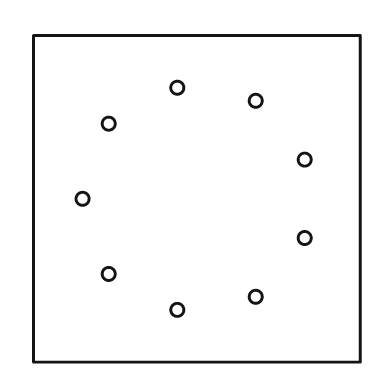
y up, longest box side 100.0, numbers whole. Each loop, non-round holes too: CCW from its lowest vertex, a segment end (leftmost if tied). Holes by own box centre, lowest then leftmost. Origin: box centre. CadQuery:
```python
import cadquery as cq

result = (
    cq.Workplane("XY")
    .moveTo(-50.0, -50.0)
    .lineTo(50.0, -50.0)
    .lineTo(50.0, 50.0)
    .lineTo(-50.0, 50.0)
    .close()
    .moveTo(-6.0, -34.0)
    .circle(2.0)
    .moveTo(18.0, -30.0)
    .circle(2.0)
    .moveTo(-27.0, -23.0)
    .circle(2.0)
    .moveTo(33.0, -12.0)
    .circle(2.0)
    .moveTo(-35.0, 0.0)
    .circle(2.0)
    .moveTo(33.0, 12.0)
    .circle(2.0)
    .moveTo(-27.0, 23.0)
    .circle(2.0)
    .moveTo(18.0, 30.0)
    .circle(2.0)
    .moveTo(-6.0, 34.0)
    .circle(2.0)
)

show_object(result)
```